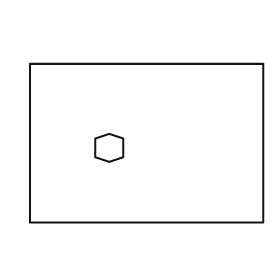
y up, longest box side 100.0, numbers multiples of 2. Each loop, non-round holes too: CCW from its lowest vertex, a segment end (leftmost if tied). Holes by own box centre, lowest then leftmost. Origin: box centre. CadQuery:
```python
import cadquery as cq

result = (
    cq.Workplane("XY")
    .moveTo(-50.0, -34.0)
    .lineTo(50.0, -34.0)
    .lineTo(50.0, 34.0)
    .lineTo(-50.0, 34.0)
    .close()
    .moveTo(-16.0, -8.0)
    .lineTo(-10.0, -6.0)
    .lineTo(-10.0, 2.0)
    .lineTo(-16.0, 4.0)
    .lineTo(-22.0, 2.0)
    .lineTo(-22.0, -6.0)
    .close()
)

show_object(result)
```